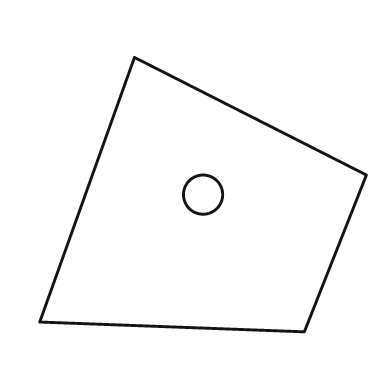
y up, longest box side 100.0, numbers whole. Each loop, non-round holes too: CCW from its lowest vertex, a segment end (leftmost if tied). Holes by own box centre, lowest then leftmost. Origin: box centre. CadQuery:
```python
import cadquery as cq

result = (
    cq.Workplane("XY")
    .moveTo(31.0, -42.0)
    .lineTo(50.0, 6.0)
    .lineTo(-21.0, 42.0)
    .lineTo(-50.0, -39.0)
    .close()
    .moveTo(0.0, 0.0)
    .circle(6.0)
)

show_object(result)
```